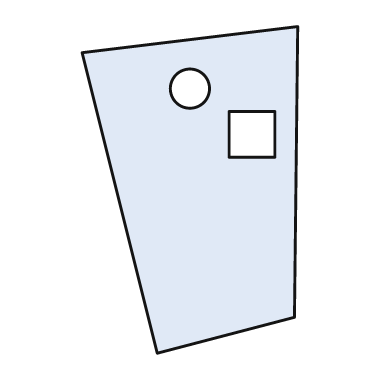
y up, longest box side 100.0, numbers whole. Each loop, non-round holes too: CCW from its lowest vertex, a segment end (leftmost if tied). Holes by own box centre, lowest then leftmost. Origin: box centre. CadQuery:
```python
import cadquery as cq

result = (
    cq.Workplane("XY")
    .moveTo(-10.0, -50.0)
    .lineTo(32.0, -39.0)
    .lineTo(33.0, 50.0)
    .lineTo(-33.0, 42.0)
    .close()
    .moveTo(12.0, 10.0)
    .lineTo(26.0, 10.0)
    .lineTo(26.0, 24.0)
    .lineTo(12.0, 24.0)
    .close()
    .moveTo(0.0, 31.0)
    .circle(6.0)
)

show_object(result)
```